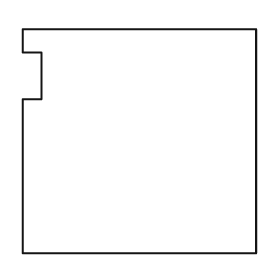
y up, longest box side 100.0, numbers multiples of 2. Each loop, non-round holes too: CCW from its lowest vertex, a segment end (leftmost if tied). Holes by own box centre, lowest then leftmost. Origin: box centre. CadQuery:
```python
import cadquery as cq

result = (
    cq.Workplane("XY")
    .moveTo(-50.0, -48.0)
    .lineTo(50.0, -48.0)
    .lineTo(50.0, 48.0)
    .lineTo(-50.0, 48.0)
    .lineTo(-50.0, 38.0)
    .lineTo(-42.0, 38.0)
    .lineTo(-42.0, 18.0)
    .lineTo(-50.0, 18.0)
    .close()
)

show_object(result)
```